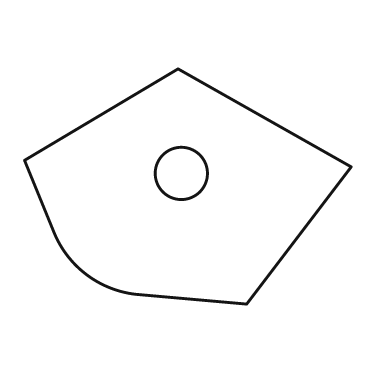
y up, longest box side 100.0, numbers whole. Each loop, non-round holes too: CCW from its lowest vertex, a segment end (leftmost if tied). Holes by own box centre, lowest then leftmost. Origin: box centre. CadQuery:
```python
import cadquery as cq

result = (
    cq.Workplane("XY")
    .moveTo(18.0, -36.0)
    .lineTo(50.0, 6.0)
    .lineTo(-3.0, 36.0)
    .lineTo(-50.0, 8.0)
    .lineTo(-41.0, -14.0)
    .threePointArc((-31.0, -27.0), (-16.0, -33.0))
    .close()
    .moveTo(-2.0, 4.0)
    .circle(8.0)
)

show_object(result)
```